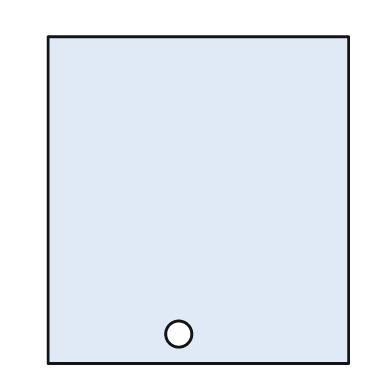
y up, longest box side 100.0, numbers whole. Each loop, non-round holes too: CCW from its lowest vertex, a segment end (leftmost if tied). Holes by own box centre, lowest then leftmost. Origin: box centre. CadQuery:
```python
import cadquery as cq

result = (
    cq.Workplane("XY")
    .moveTo(-46.0, -50.0)
    .lineTo(46.0, -50.0)
    .lineTo(46.0, 50.0)
    .lineTo(-46.0, 50.0)
    .close()
    .moveTo(-6.0, -41.0)
    .circle(4.0)
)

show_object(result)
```